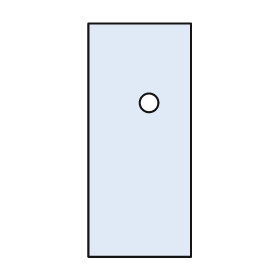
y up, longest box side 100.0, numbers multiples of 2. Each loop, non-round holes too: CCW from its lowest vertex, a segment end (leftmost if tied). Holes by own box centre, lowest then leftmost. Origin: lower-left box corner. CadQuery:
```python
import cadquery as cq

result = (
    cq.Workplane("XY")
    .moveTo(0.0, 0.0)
    .lineTo(44.0, 0.0)
    .lineTo(44.0, 100.0)
    .lineTo(0.0, 100.0)
    .close()
    .moveTo(26.0, 66.0)
    .circle(4.0)
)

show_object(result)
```